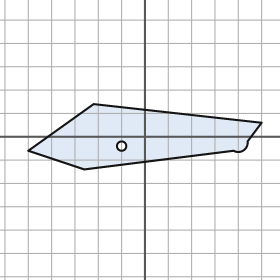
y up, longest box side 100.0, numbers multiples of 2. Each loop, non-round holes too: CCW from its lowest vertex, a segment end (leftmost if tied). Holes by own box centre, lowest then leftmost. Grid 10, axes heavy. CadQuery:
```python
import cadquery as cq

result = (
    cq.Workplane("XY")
    .moveTo(-26.0, -14.0)
    .lineTo(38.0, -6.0)
    .threePointArc((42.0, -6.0), (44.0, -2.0))
    .lineTo(50.0, 6.0)
    .lineTo(-22.0, 14.0)
    .lineTo(-50.0, -6.0)
    .close()
    .moveTo(-10.0, -4.0)
    .circle(2.0)
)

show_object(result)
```